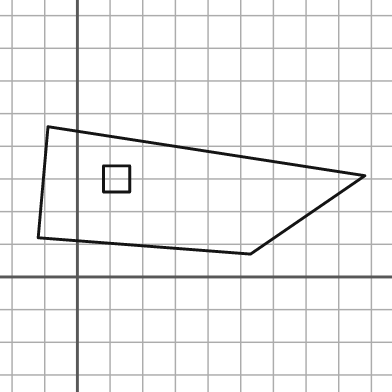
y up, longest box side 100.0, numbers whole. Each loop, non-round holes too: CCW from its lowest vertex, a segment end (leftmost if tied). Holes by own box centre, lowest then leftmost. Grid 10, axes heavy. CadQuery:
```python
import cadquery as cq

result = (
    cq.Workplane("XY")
    .moveTo(53.0, 7.0)
    .lineTo(88.0, 31.0)
    .lineTo(-9.0, 46.0)
    .lineTo(-12.0, 12.0)
    .close()
    .moveTo(8.0, 26.0)
    .lineTo(16.0, 26.0)
    .lineTo(16.0, 34.0)
    .lineTo(8.0, 34.0)
    .close()
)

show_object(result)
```